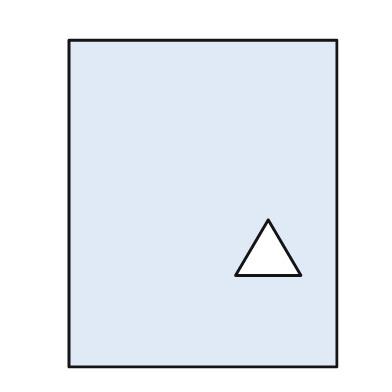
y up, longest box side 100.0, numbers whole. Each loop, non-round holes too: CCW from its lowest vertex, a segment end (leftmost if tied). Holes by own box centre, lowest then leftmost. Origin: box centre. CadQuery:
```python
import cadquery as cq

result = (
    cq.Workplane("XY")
    .moveTo(-41.0, -50.0)
    .lineTo(41.0, -50.0)
    .lineTo(41.0, 50.0)
    .lineTo(-41.0, 50.0)
    .close()
    .moveTo(10.0, -22.0)
    .lineTo(30.0, -22.0)
    .lineTo(20.0, -5.0)
    .close()
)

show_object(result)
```